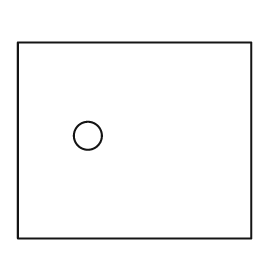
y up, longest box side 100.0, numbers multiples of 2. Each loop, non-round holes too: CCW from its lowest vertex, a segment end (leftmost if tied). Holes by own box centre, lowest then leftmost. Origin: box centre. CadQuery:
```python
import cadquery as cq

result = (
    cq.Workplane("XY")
    .moveTo(-50.0, -42.0)
    .lineTo(50.0, -42.0)
    .lineTo(50.0, 42.0)
    .lineTo(-50.0, 42.0)
    .close()
    .moveTo(-20.0, 2.0)
    .circle(6.0)
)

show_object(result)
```